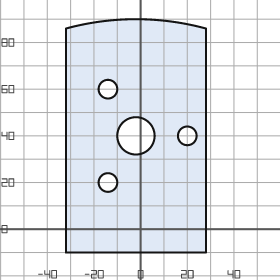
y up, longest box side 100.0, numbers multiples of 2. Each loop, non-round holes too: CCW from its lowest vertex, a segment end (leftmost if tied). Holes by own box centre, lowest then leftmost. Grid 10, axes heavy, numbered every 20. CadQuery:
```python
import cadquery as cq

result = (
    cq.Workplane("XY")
    .moveTo(-32.0, -10.0)
    .lineTo(28.0, -10.0)
    .lineTo(28.0, 86.0)
    .threePointArc((-2.0, 90.0), (-32.0, 86.0))
    .close()
    .moveTo(-14.0, 20.0)
    .circle(4.0)
    .moveTo(-2.0, 40.0)
    .circle(8.0)
    .moveTo(20.0, 40.0)
    .circle(4.0)
    .moveTo(-14.0, 60.0)
    .circle(4.0)
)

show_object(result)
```